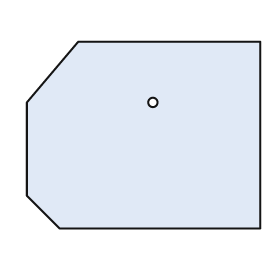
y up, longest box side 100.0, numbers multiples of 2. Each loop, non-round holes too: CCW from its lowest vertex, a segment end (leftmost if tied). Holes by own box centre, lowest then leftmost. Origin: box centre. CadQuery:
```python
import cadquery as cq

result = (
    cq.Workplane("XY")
    .moveTo(-36.0, -40.0)
    .lineTo(50.0, -40.0)
    .lineTo(50.0, 40.0)
    .lineTo(-28.0, 40.0)
    .lineTo(-50.0, 14.0)
    .lineTo(-50.0, -26.0)
    .close()
    .moveTo(4.0, 14.0)
    .circle(2.0)
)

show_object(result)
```